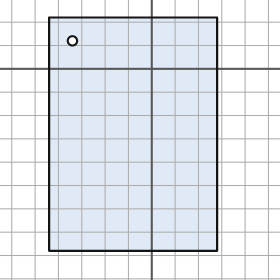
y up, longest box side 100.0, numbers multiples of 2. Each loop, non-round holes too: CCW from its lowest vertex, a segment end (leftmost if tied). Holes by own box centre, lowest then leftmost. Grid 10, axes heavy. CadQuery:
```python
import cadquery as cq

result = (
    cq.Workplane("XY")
    .moveTo(-44.0, -78.0)
    .lineTo(28.0, -78.0)
    .lineTo(28.0, 22.0)
    .lineTo(-44.0, 22.0)
    .close()
    .moveTo(-34.0, 12.0)
    .circle(2.0)
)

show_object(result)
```